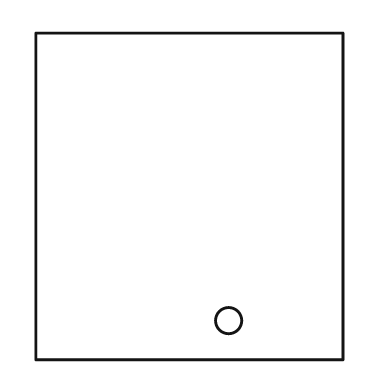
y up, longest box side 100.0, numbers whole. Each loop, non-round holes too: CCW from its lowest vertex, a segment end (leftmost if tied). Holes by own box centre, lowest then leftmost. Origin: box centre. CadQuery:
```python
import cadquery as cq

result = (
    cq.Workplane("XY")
    .moveTo(-47.0, -50.0)
    .lineTo(47.0, -50.0)
    .lineTo(47.0, 50.0)
    .lineTo(-47.0, 50.0)
    .close()
    .moveTo(12.0, -38.0)
    .circle(4.0)
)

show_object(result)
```